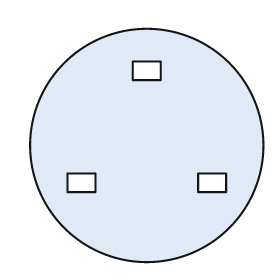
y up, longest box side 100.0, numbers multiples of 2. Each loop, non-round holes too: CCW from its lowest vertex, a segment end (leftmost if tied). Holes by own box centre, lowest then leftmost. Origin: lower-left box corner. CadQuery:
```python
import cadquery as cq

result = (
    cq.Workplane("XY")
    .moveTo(50.0, 50.0)
    .circle(50.0)
    .moveTo(16.0, 30.0)
    .lineTo(28.0, 30.0)
    .lineTo(28.0, 38.0)
    .lineTo(16.0, 38.0)
    .close()
    .moveTo(72.0, 30.0)
    .lineTo(84.0, 30.0)
    .lineTo(84.0, 38.0)
    .lineTo(72.0, 38.0)
    .close()
    .moveTo(44.0, 78.0)
    .lineTo(56.0, 78.0)
    .lineTo(56.0, 86.0)
    .lineTo(44.0, 86.0)
    .close()
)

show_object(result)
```